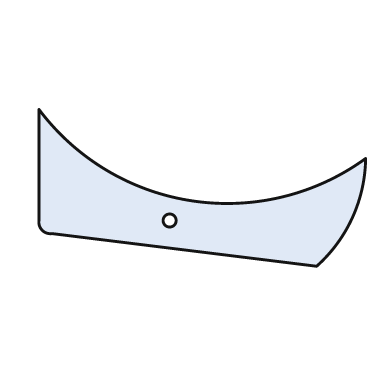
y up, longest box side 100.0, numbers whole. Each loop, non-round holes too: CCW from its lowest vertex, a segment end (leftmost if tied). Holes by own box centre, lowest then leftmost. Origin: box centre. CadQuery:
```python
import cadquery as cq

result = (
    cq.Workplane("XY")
    .moveTo(35.0, -24.0)
    .threePointArc((46.0, -9.0), (50.0, 9.0))
    .threePointArc((-3.0, -4.0), (-50.0, 24.0))
    .lineTo(-50.0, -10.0)
    .threePointArc((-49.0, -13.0), (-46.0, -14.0))
    .close()
    .moveTo(-10.0, -10.0)
    .circle(2.0)
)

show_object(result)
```